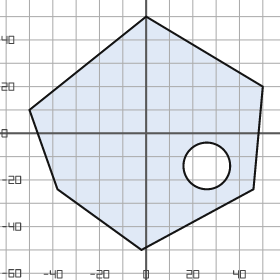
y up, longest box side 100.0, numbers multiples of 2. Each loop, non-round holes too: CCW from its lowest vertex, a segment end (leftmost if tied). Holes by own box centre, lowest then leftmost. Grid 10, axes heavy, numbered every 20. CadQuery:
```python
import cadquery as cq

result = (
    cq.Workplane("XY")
    .moveTo(-2.0, -50.0)
    .lineTo(46.0, -24.0)
    .lineTo(50.0, 20.0)
    .lineTo(0.0, 50.0)
    .lineTo(-50.0, 10.0)
    .lineTo(-38.0, -24.0)
    .close()
    .moveTo(26.0, -14.0)
    .circle(10.0)
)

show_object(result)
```